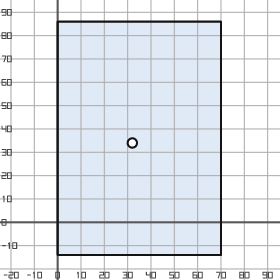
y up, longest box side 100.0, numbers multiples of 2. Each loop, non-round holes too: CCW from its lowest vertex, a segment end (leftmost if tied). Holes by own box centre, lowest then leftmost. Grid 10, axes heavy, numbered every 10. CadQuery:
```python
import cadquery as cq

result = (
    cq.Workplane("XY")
    .moveTo(0.0, -14.0)
    .lineTo(70.0, -14.0)
    .lineTo(70.0, 86.0)
    .lineTo(0.0, 86.0)
    .close()
    .moveTo(32.0, 34.0)
    .circle(2.0)
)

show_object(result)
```